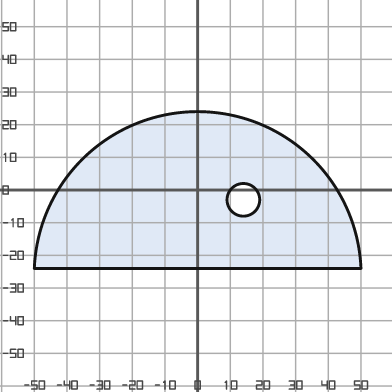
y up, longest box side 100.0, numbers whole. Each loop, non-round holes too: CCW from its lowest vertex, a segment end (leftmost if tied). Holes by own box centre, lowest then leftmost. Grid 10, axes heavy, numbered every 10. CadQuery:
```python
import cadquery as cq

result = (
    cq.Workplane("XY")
    .moveTo(-50.0, -24.0)
    .lineTo(50.0, -24.0)
    .threePointArc((0.0, 24.0), (-50.0, -24.0))
    .close()
    .moveTo(14.0, -3.0)
    .circle(5.0)
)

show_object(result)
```